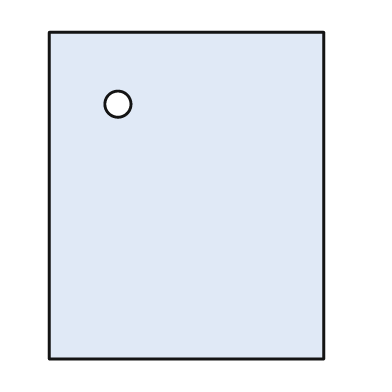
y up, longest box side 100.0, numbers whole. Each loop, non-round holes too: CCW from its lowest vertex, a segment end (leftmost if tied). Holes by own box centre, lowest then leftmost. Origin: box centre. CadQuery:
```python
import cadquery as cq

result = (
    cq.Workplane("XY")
    .moveTo(-42.0, -50.0)
    .lineTo(42.0, -50.0)
    .lineTo(42.0, 50.0)
    .lineTo(-42.0, 50.0)
    .close()
    .moveTo(-21.0, 28.0)
    .circle(4.0)
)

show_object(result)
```